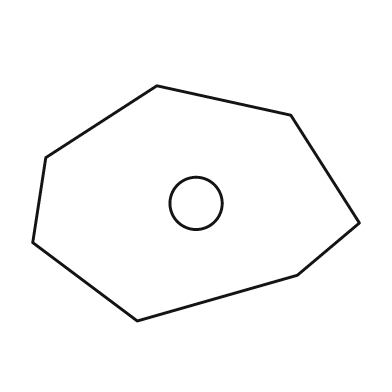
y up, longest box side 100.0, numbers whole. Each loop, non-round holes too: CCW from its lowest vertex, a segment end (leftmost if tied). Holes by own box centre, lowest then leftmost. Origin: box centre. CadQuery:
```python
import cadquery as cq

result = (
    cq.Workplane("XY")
    .moveTo(-18.0, -36.0)
    .lineTo(31.0, -22.0)
    .lineTo(50.0, -6.0)
    .lineTo(29.0, 27.0)
    .lineTo(-12.0, 36.0)
    .lineTo(-46.0, 14.0)
    .lineTo(-50.0, -12.0)
    .close()
    .moveTo(0.0, 0.0)
    .circle(8.0)
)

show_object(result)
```